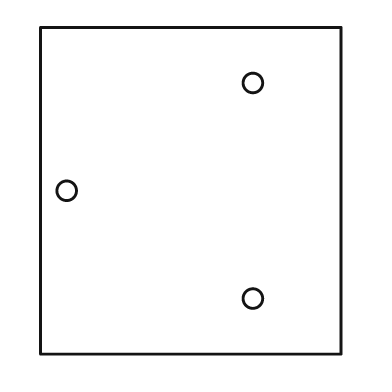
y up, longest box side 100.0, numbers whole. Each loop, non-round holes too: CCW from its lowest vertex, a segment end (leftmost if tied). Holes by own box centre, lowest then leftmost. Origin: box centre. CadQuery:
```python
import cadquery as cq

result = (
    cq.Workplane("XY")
    .moveTo(-46.0, -50.0)
    .lineTo(46.0, -50.0)
    .lineTo(46.0, 50.0)
    .lineTo(-46.0, 50.0)
    .close()
    .moveTo(19.0, -33.0)
    .circle(3.0)
    .moveTo(-38.0, 0.0)
    .circle(3.0)
    .moveTo(19.0, 33.0)
    .circle(3.0)
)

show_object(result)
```